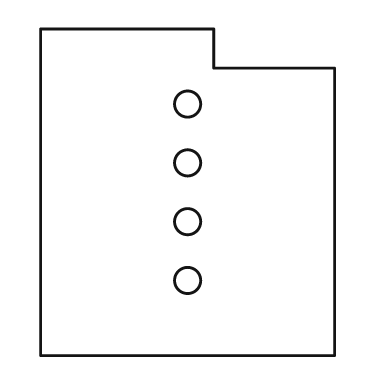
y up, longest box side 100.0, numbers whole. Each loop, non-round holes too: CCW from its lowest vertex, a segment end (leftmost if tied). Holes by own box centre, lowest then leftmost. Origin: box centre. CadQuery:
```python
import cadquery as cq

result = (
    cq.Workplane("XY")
    .moveTo(-45.0, -50.0)
    .lineTo(45.0, -50.0)
    .lineTo(45.0, 38.0)
    .lineTo(8.0, 38.0)
    .lineTo(8.0, 50.0)
    .lineTo(-45.0, 50.0)
    .close()
    .moveTo(0.0, -27.0)
    .circle(4.0)
    .moveTo(0.0, -9.0)
    .circle(4.0)
    .moveTo(0.0, 9.0)
    .circle(4.0)
    .moveTo(0.0, 27.0)
    .circle(4.0)
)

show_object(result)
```